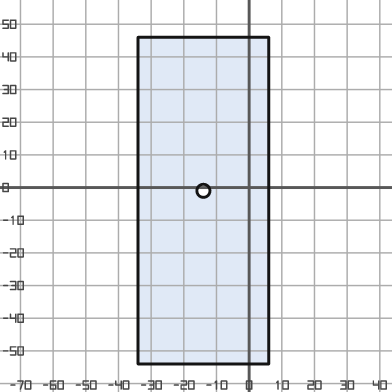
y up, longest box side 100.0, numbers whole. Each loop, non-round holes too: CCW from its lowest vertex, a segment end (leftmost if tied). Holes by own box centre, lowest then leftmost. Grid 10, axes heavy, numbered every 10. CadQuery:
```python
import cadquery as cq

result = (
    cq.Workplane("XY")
    .moveTo(-34.0, -54.0)
    .lineTo(6.0, -54.0)
    .lineTo(6.0, 46.0)
    .lineTo(-34.0, 46.0)
    .close()
    .moveTo(-14.0, -1.0)
    .circle(2.0)
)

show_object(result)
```